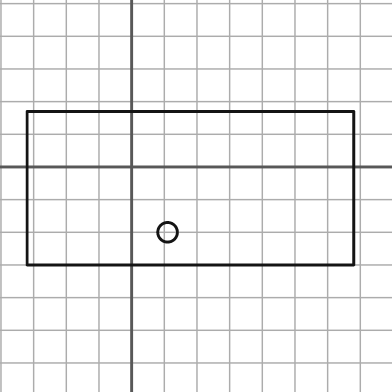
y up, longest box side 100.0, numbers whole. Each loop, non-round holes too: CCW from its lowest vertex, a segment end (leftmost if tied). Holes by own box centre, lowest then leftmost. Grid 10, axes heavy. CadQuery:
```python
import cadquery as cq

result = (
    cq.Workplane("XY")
    .moveTo(-32.0, -30.0)
    .lineTo(68.0, -30.0)
    .lineTo(68.0, 17.0)
    .lineTo(-32.0, 17.0)
    .close()
    .moveTo(11.0, -20.0)
    .circle(3.0)
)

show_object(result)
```